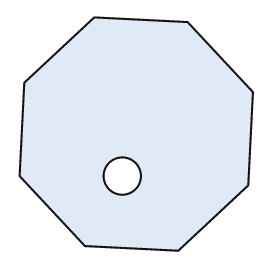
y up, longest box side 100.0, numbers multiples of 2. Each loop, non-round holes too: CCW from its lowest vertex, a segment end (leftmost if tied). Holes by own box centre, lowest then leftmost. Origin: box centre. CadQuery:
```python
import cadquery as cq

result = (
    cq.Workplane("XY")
    .moveTo(18.0, -50.0)
    .lineTo(48.0, -22.0)
    .lineTo(50.0, 18.0)
    .lineTo(22.0, 48.0)
    .lineTo(-18.0, 50.0)
    .lineTo(-48.0, 22.0)
    .lineTo(-50.0, -18.0)
    .lineTo(-22.0, -48.0)
    .close()
    .moveTo(-6.0, -18.0)
    .circle(8.0)
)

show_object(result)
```